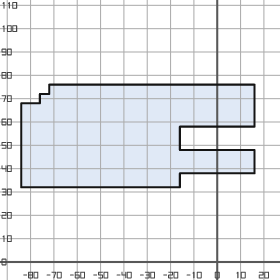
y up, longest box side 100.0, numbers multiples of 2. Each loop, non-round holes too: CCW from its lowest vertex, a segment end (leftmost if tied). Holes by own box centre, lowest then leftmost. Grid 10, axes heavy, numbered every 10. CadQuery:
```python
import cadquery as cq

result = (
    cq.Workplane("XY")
    .moveTo(-84.0, 32.0)
    .lineTo(-16.0, 32.0)
    .lineTo(-16.0, 38.0)
    .lineTo(16.0, 38.0)
    .lineTo(16.0, 48.0)
    .lineTo(-16.0, 48.0)
    .lineTo(-16.0, 58.0)
    .lineTo(16.0, 58.0)
    .lineTo(16.0, 76.0)
    .lineTo(-72.0, 76.0)
    .lineTo(-72.0, 72.0)
    .lineTo(-76.0, 72.0)
    .lineTo(-76.0, 68.0)
    .lineTo(-84.0, 68.0)
    .close()
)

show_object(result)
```